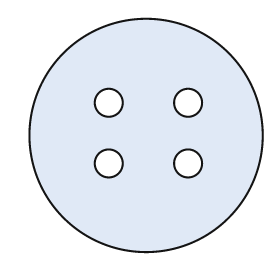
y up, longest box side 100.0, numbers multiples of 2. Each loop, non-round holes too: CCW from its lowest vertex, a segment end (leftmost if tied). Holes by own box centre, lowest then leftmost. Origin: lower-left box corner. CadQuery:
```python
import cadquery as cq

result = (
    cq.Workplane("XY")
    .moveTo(50.0, 50.0)
    .circle(50.0)
    .moveTo(34.0, 38.0)
    .circle(6.0)
    .moveTo(68.0, 38.0)
    .circle(6.0)
    .moveTo(34.0, 64.0)
    .circle(6.0)
    .moveTo(68.0, 64.0)
    .circle(6.0)
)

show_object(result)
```